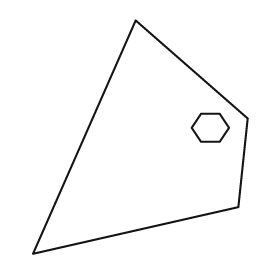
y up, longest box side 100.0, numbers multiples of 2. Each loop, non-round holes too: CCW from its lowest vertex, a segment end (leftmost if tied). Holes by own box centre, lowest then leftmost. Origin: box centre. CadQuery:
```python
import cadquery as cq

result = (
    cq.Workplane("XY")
    .moveTo(-46.0, -50.0)
    .lineTo(42.0, -30.0)
    .lineTo(46.0, 8.0)
    .lineTo(-2.0, 50.0)
    .close()
    .moveTo(26.0, -2.0)
    .lineTo(34.0, -2.0)
    .lineTo(38.0, 4.0)
    .lineTo(34.0, 10.0)
    .lineTo(26.0, 10.0)
    .lineTo(22.0, 4.0)
    .close()
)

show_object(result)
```